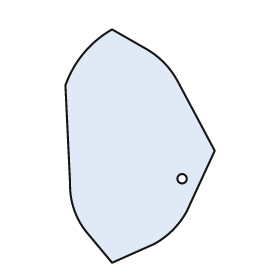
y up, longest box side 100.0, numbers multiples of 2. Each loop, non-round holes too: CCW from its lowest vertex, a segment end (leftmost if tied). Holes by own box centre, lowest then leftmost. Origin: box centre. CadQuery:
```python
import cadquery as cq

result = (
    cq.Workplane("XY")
    .moveTo(-12.0, -50.0)
    .lineTo(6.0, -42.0)
    .threePointArc((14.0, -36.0), (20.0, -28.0))
    .lineTo(32.0, -2.0)
    .lineTo(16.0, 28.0)
    .threePointArc((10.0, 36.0), (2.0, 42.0))
    .lineTo(-12.0, 50.0)
    .threePointArc((-24.0, 40.0), (-32.0, 26.0))
    .lineTo(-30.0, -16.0)
    .threePointArc((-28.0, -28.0), (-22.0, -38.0))
    .close()
    .moveTo(18.0, -14.0)
    .circle(2.0)
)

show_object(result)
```